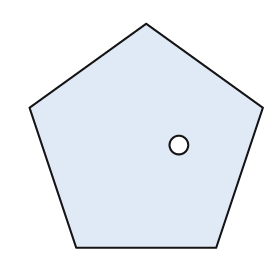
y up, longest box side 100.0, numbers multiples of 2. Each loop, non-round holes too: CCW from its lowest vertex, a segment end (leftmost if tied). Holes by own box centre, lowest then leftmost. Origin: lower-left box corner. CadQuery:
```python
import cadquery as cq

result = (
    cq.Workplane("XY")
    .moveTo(20.0, 0.0)
    .lineTo(80.0, 0.0)
    .lineTo(100.0, 60.0)
    .lineTo(50.0, 96.0)
    .lineTo(0.0, 60.0)
    .close()
    .moveTo(64.0, 44.0)
    .circle(4.0)
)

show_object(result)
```